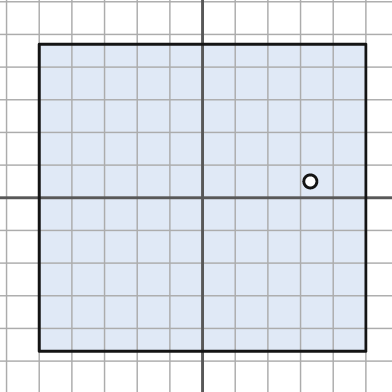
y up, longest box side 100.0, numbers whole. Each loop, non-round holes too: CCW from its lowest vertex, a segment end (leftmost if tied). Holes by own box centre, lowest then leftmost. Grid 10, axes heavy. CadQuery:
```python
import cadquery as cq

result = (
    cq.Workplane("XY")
    .moveTo(-50.0, -47.0)
    .lineTo(50.0, -47.0)
    .lineTo(50.0, 47.0)
    .lineTo(-50.0, 47.0)
    .close()
    .moveTo(33.0, 5.0)
    .circle(2.0)
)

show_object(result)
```